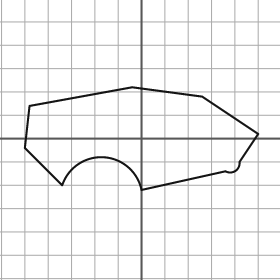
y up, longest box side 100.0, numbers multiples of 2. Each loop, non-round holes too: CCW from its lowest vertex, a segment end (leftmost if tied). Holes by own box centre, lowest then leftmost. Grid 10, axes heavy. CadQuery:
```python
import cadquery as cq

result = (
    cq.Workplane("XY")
    .moveTo(0.0, -22.0)
    .lineTo(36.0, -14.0)
    .threePointArc((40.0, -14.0), (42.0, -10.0))
    .lineTo(50.0, 2.0)
    .lineTo(26.0, 18.0)
    .lineTo(-4.0, 22.0)
    .lineTo(-48.0, 14.0)
    .lineTo(-50.0, -4.0)
    .lineTo(-34.0, -20.0)
    .threePointArc((-16.0, -8.0), (0.0, -22.0))
    .close()
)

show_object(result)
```